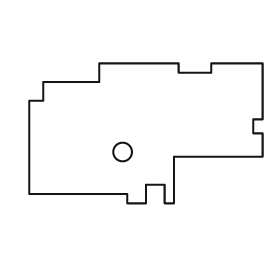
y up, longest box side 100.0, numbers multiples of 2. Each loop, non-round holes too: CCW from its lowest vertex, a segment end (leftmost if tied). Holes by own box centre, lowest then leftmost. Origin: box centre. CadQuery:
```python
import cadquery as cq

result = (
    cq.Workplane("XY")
    .moveTo(-8.0, -30.0)
    .lineTo(0.0, -30.0)
    .lineTo(0.0, -22.0)
    .lineTo(8.0, -22.0)
    .lineTo(8.0, -30.0)
    .lineTo(12.0, -30.0)
    .lineTo(12.0, -10.0)
    .lineTo(50.0, -10.0)
    .lineTo(50.0, 0.0)
    .lineTo(46.0, 0.0)
    .lineTo(46.0, 6.0)
    .lineTo(50.0, 6.0)
    .lineTo(50.0, 30.0)
    .lineTo(28.0, 30.0)
    .lineTo(28.0, 26.0)
    .lineTo(14.0, 26.0)
    .lineTo(14.0, 30.0)
    .lineTo(-20.0, 30.0)
    .lineTo(-20.0, 22.0)
    .lineTo(-44.0, 22.0)
    .lineTo(-44.0, 14.0)
    .lineTo(-50.0, 14.0)
    .lineTo(-50.0, -26.0)
    .lineTo(-8.0, -26.0)
    .close()
    .moveTo(-10.0, -8.0)
    .circle(4.0)
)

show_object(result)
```